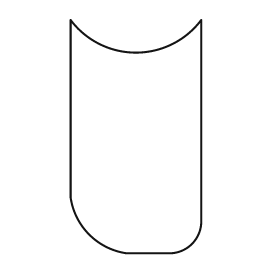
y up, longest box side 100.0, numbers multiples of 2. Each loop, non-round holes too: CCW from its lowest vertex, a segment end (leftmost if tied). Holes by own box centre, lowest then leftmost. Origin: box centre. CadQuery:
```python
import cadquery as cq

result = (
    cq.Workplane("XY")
    .moveTo(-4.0, -50.0)
    .lineTo(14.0, -50.0)
    .threePointArc((24.0, -46.0), (28.0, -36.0))
    .lineTo(28.0, 50.0)
    .threePointArc((0.0, 36.0), (-28.0, 50.0))
    .lineTo(-28.0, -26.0)
    .threePointArc((-20.0, -42.0), (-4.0, -50.0))
    .close()
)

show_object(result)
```